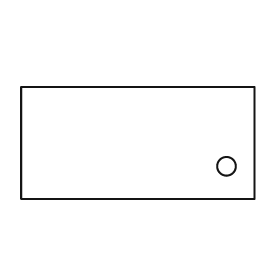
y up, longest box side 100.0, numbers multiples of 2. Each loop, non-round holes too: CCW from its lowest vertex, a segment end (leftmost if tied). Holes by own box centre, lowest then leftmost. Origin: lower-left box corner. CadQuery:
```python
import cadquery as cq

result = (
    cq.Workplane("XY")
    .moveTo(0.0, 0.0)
    .lineTo(100.0, 0.0)
    .lineTo(100.0, 48.0)
    .lineTo(0.0, 48.0)
    .close()
    .moveTo(88.0, 14.0)
    .circle(4.0)
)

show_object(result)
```